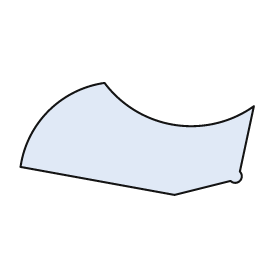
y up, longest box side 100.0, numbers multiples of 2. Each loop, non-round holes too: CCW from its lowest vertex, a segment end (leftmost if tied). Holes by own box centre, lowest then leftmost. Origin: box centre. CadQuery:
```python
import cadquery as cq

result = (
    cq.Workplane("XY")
    .moveTo(16.0, -24.0)
    .lineTo(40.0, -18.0)
    .threePointArc((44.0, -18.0), (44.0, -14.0))
    .lineTo(50.0, 14.0)
    .threePointArc((16.0, 6.0), (-14.0, 24.0))
    .threePointArc((-38.0, 12.0), (-50.0, -12.0))
    .close()
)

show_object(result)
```